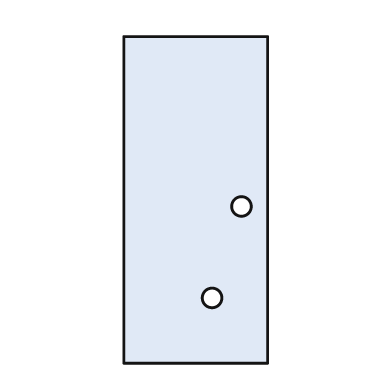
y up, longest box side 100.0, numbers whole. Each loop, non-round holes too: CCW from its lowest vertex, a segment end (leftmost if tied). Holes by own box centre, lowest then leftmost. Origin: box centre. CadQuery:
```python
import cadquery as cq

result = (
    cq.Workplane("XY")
    .moveTo(-22.0, -50.0)
    .lineTo(22.0, -50.0)
    .lineTo(22.0, 50.0)
    .lineTo(-22.0, 50.0)
    .close()
    .moveTo(5.0, -30.0)
    .circle(3.0)
    .moveTo(14.0, -2.0)
    .circle(3.0)
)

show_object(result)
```